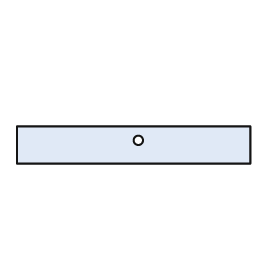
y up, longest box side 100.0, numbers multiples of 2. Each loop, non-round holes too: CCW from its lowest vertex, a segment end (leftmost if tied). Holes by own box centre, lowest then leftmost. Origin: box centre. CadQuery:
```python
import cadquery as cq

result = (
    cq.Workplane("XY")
    .moveTo(-50.0, -8.0)
    .lineTo(50.0, -8.0)
    .lineTo(50.0, 8.0)
    .lineTo(-50.0, 8.0)
    .close()
    .moveTo(2.0, 2.0)
    .circle(2.0)
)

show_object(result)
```